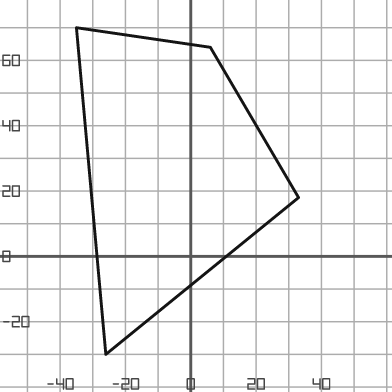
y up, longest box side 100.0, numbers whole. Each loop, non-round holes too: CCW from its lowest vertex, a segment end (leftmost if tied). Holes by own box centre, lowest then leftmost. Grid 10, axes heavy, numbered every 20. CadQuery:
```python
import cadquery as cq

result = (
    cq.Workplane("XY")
    .moveTo(-26.0, -30.0)
    .lineTo(33.0, 18.0)
    .lineTo(6.0, 64.0)
    .lineTo(-35.0, 70.0)
    .close()
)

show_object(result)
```